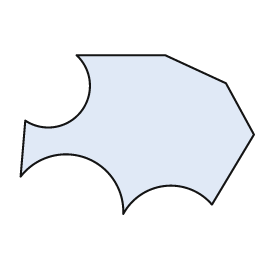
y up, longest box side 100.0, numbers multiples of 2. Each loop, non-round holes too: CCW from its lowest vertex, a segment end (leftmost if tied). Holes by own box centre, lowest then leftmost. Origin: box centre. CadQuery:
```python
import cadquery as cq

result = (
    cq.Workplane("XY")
    .moveTo(-6.0, -34.0)
    .threePointArc((12.0, -22.0), (32.0, -30.0))
    .lineTo(50.0, 0.0)
    .lineTo(38.0, 22.0)
    .lineTo(12.0, 34.0)
    .lineTo(-26.0, 34.0)
    .threePointArc((-24.0, 10.0), (-48.0, 6.0))
    .lineTo(-50.0, -18.0)
    .threePointArc((-22.0, -10.0), (-6.0, -34.0))
    .close()
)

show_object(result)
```